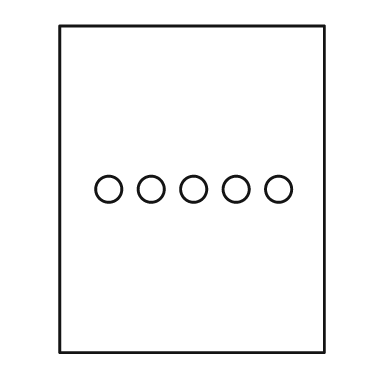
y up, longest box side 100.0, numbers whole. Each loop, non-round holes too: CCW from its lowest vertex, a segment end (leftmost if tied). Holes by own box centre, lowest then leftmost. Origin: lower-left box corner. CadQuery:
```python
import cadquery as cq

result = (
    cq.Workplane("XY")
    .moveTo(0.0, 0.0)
    .lineTo(81.0, 0.0)
    .lineTo(81.0, 100.0)
    .lineTo(0.0, 100.0)
    .close()
    .moveTo(15.0, 50.0)
    .circle(4.0)
    .moveTo(28.0, 50.0)
    .circle(4.0)
    .moveTo(41.0, 50.0)
    .circle(4.0)
    .moveTo(54.0, 50.0)
    .circle(4.0)
    .moveTo(67.0, 50.0)
    .circle(4.0)
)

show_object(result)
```